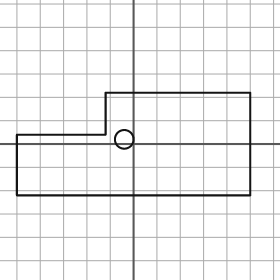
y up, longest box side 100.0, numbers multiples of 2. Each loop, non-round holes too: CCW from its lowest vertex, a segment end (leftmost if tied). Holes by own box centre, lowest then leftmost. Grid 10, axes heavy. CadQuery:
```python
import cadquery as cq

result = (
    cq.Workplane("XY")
    .moveTo(-50.0, -22.0)
    .lineTo(50.0, -22.0)
    .lineTo(50.0, 22.0)
    .lineTo(-12.0, 22.0)
    .lineTo(-12.0, 4.0)
    .lineTo(-50.0, 4.0)
    .close()
    .moveTo(-4.0, 2.0)
    .circle(4.0)
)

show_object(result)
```